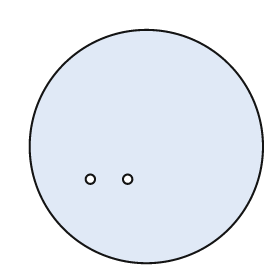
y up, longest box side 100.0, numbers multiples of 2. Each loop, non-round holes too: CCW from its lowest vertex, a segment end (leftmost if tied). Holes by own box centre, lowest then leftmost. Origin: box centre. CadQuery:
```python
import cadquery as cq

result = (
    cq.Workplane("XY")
    .moveTo(0.0, 0.0)
    .circle(50.0)
    .moveTo(-24.0, -14.0)
    .circle(2.0)
    .moveTo(-8.0, -14.0)
    .circle(2.0)
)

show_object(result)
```